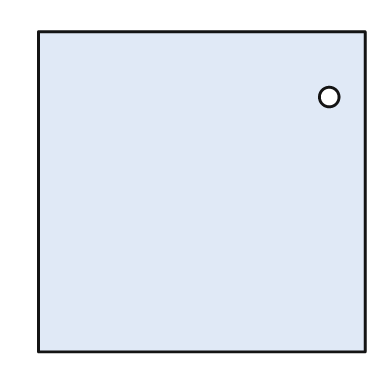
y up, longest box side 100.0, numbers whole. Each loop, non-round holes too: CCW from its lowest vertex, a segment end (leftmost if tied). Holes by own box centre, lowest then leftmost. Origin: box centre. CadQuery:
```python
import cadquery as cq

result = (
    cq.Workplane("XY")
    .moveTo(-50.0, -49.0)
    .lineTo(50.0, -49.0)
    .lineTo(50.0, 49.0)
    .lineTo(-50.0, 49.0)
    .close()
    .moveTo(39.0, 29.0)
    .circle(3.0)
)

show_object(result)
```